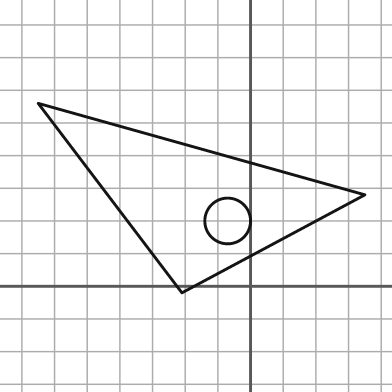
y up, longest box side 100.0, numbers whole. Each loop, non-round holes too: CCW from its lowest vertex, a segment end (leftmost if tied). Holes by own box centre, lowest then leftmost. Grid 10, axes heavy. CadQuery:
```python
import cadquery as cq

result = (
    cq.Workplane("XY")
    .moveTo(-21.0, -2.0)
    .lineTo(35.0, 28.0)
    .lineTo(-65.0, 56.0)
    .close()
    .moveTo(-7.0, 20.0)
    .circle(7.0)
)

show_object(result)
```